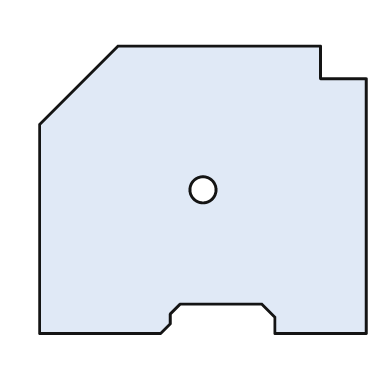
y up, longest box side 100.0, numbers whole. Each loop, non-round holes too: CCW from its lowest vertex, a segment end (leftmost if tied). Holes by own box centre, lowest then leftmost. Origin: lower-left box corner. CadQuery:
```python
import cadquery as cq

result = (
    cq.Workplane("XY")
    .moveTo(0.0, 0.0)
    .lineTo(37.0, 0.0)
    .lineTo(40.0, 3.0)
    .lineTo(40.0, 6.0)
    .lineTo(43.0, 9.0)
    .lineTo(68.0, 9.0)
    .lineTo(72.0, 5.0)
    .lineTo(72.0, 0.0)
    .lineTo(100.0, 0.0)
    .lineTo(100.0, 78.0)
    .lineTo(86.0, 78.0)
    .lineTo(86.0, 88.0)
    .lineTo(24.0, 88.0)
    .lineTo(0.0, 64.0)
    .close()
    .moveTo(50.0, 44.0)
    .circle(4.0)
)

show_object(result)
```